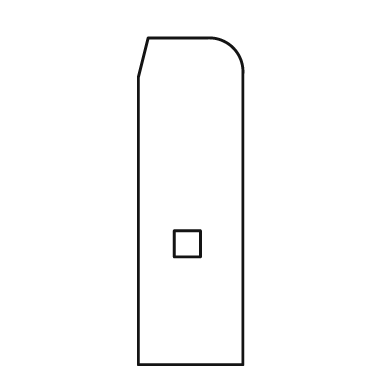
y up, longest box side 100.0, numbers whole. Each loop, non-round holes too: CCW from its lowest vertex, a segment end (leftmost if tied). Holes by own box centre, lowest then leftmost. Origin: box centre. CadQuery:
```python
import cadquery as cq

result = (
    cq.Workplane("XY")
    .moveTo(-16.0, -50.0)
    .lineTo(16.0, -50.0)
    .lineTo(16.0, 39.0)
    .threePointArc((13.0, 47.0), (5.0, 50.0))
    .lineTo(-13.0, 50.0)
    .lineTo(-16.0, 38.0)
    .close()
    .moveTo(-5.0, -17.0)
    .lineTo(3.0, -17.0)
    .lineTo(3.0, -9.0)
    .lineTo(-5.0, -9.0)
    .close()
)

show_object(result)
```